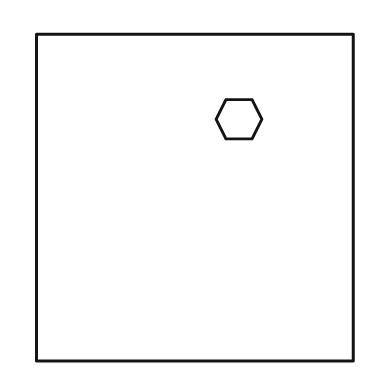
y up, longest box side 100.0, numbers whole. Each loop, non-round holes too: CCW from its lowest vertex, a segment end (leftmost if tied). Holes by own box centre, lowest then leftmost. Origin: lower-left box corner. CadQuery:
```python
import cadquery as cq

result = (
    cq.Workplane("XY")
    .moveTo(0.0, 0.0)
    .lineTo(97.0, 0.0)
    .lineTo(97.0, 100.0)
    .lineTo(0.0, 100.0)
    .close()
    .moveTo(58.0, 68.0)
    .lineTo(66.0, 68.0)
    .lineTo(69.0, 74.0)
    .lineTo(66.0, 80.0)
    .lineTo(58.0, 80.0)
    .lineTo(55.0, 74.0)
    .close()
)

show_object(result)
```